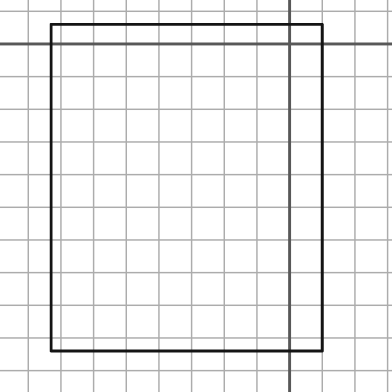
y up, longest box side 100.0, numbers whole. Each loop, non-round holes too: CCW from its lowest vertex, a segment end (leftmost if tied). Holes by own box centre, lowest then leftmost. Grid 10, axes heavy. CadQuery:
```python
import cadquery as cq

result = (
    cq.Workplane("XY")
    .moveTo(-73.0, -94.0)
    .lineTo(10.0, -94.0)
    .lineTo(10.0, 6.0)
    .lineTo(-73.0, 6.0)
    .close()
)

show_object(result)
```